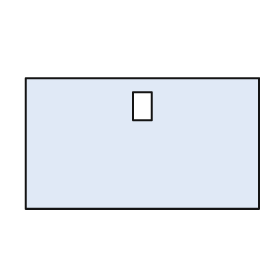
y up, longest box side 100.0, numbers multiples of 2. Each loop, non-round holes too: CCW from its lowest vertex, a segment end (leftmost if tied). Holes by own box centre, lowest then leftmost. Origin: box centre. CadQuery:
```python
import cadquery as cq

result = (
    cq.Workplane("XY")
    .moveTo(-50.0, -28.0)
    .lineTo(50.0, -28.0)
    .lineTo(50.0, 28.0)
    .lineTo(-50.0, 28.0)
    .close()
    .moveTo(-4.0, 10.0)
    .lineTo(4.0, 10.0)
    .lineTo(4.0, 22.0)
    .lineTo(-4.0, 22.0)
    .close()
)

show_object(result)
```